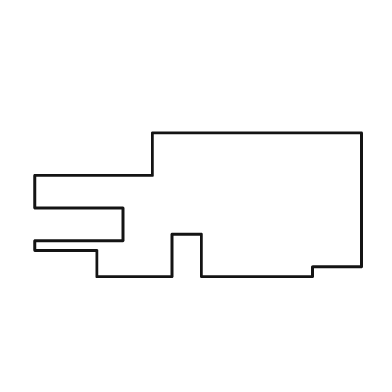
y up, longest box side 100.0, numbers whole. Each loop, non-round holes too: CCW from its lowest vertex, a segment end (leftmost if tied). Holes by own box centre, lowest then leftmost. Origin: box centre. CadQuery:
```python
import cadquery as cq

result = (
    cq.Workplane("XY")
    .moveTo(-31.0, -22.0)
    .lineTo(-8.0, -22.0)
    .lineTo(-8.0, -9.0)
    .lineTo(1.0, -9.0)
    .lineTo(1.0, -22.0)
    .lineTo(35.0, -22.0)
    .lineTo(35.0, -19.0)
    .lineTo(50.0, -19.0)
    .lineTo(50.0, 22.0)
    .lineTo(-14.0, 22.0)
    .lineTo(-14.0, 9.0)
    .lineTo(-50.0, 9.0)
    .lineTo(-50.0, -1.0)
    .lineTo(-23.0, -1.0)
    .lineTo(-23.0, -11.0)
    .lineTo(-50.0, -11.0)
    .lineTo(-50.0, -14.0)
    .lineTo(-31.0, -14.0)
    .close()
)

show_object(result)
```